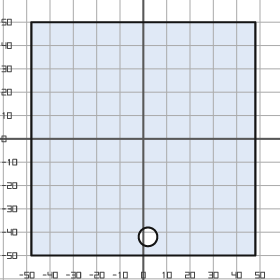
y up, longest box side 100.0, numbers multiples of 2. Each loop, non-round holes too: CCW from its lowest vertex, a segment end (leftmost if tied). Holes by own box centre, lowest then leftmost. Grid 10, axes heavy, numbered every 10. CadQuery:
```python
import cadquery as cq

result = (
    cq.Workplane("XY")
    .moveTo(-48.0, -50.0)
    .lineTo(48.0, -50.0)
    .lineTo(48.0, 50.0)
    .lineTo(-48.0, 50.0)
    .close()
    .moveTo(2.0, -42.0)
    .circle(4.0)
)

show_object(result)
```